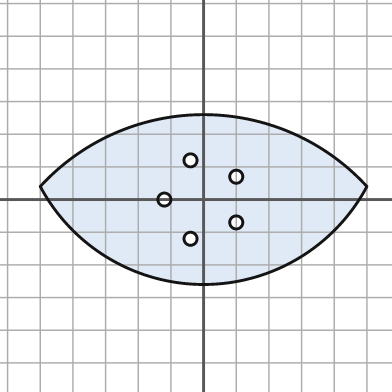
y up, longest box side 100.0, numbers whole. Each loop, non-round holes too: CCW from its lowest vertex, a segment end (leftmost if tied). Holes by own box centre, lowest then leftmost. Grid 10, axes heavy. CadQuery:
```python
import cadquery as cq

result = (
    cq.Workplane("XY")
    .moveTo(-50.0, 4.0)
    .threePointArc((0.0, -26.0), (50.0, 4.0))
    .threePointArc((0.0, 26.0), (-50.0, 4.0))
    .close()
    .moveTo(-4.0, -12.0)
    .circle(2.0)
    .moveTo(10.0, -7.0)
    .circle(2.0)
    .moveTo(-12.0, 0.0)
    .circle(2.0)
    .moveTo(10.0, 7.0)
    .circle(2.0)
    .moveTo(-4.0, 12.0)
    .circle(2.0)
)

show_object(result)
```